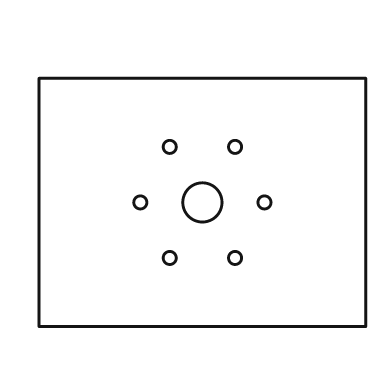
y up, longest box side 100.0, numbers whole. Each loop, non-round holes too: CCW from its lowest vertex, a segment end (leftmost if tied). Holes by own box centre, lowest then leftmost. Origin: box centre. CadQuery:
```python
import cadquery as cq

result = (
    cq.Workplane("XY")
    .moveTo(-50.0, -38.0)
    .lineTo(50.0, -38.0)
    .lineTo(50.0, 38.0)
    .lineTo(-50.0, 38.0)
    .close()
    .moveTo(-10.0, -17.0)
    .circle(2.0)
    .moveTo(10.0, -17.0)
    .circle(2.0)
    .moveTo(-19.0, 0.0)
    .circle(2.0)
    .moveTo(0.0, 0.0)
    .circle(6.0)
    .moveTo(19.0, 0.0)
    .circle(2.0)
    .moveTo(-10.0, 17.0)
    .circle(2.0)
    .moveTo(10.0, 17.0)
    .circle(2.0)
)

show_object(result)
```